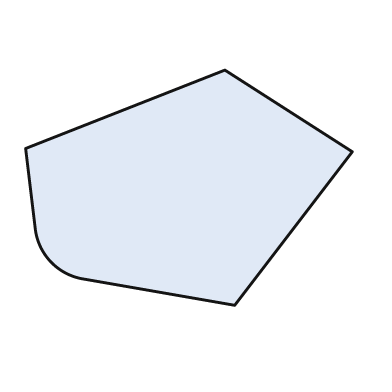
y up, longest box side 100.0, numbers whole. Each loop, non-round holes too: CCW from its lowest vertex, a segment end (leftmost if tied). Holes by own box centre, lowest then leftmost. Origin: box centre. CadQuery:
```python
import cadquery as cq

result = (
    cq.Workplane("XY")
    .moveTo(14.0, -36.0)
    .lineTo(50.0, 11.0)
    .lineTo(11.0, 36.0)
    .lineTo(-50.0, 12.0)
    .lineTo(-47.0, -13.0)
    .threePointArc((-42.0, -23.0), (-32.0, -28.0))
    .close()
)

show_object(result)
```